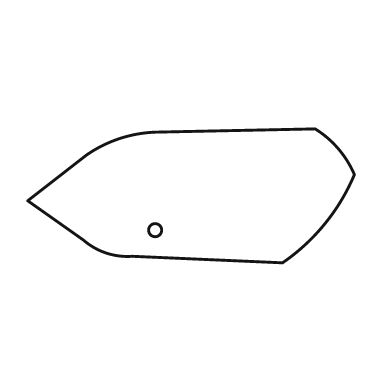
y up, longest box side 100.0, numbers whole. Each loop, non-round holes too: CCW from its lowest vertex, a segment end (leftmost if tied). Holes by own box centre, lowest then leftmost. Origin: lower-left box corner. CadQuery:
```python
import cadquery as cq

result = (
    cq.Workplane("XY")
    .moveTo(78.0, 0.0)
    .threePointArc((91.0, 12.0), (100.0, 27.0))
    .threePointArc((95.0, 35.0), (88.0, 41.0))
    .lineTo(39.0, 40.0)
    .threePointArc((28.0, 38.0), (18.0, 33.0))
    .lineTo(0.0, 19.0)
    .lineTo(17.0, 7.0)
    .threePointArc((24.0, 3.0), (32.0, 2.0))
    .close()
    .moveTo(39.0, 10.0)
    .circle(2.0)
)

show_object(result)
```